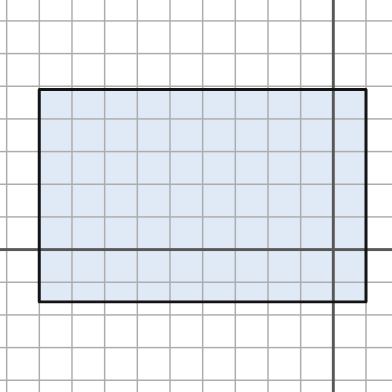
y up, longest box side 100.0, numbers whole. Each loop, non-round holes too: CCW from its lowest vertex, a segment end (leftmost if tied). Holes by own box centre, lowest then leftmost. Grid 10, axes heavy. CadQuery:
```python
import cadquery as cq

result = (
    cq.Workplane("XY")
    .moveTo(-90.0, -16.0)
    .lineTo(10.0, -16.0)
    .lineTo(10.0, 49.0)
    .lineTo(-90.0, 49.0)
    .close()
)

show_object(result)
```